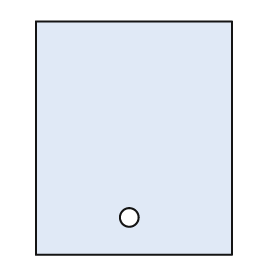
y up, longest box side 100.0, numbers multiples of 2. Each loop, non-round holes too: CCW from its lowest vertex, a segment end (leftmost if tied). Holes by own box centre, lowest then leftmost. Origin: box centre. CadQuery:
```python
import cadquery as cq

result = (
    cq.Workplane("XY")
    .moveTo(-42.0, -50.0)
    .lineTo(42.0, -50.0)
    .lineTo(42.0, 50.0)
    .lineTo(-42.0, 50.0)
    .close()
    .moveTo(-2.0, -34.0)
    .circle(4.0)
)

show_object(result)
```